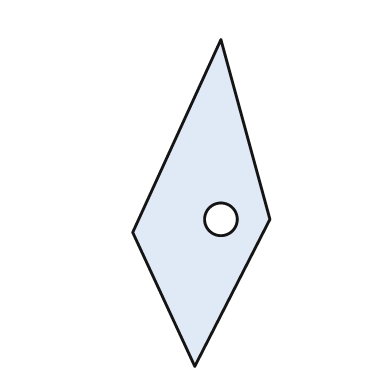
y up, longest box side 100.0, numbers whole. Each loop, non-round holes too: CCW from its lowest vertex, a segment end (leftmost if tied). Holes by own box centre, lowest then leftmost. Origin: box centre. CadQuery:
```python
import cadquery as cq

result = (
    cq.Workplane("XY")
    .moveTo(-2.0, -50.0)
    .lineTo(21.0, -5.0)
    .lineTo(6.0, 50.0)
    .lineTo(-21.0, -9.0)
    .close()
    .moveTo(6.0, -5.0)
    .circle(5.0)
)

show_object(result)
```